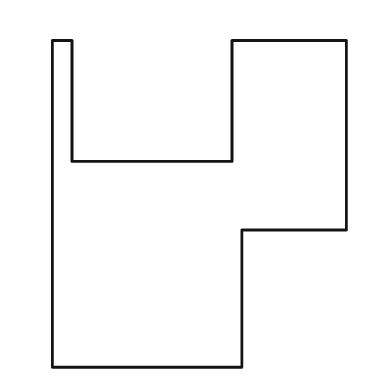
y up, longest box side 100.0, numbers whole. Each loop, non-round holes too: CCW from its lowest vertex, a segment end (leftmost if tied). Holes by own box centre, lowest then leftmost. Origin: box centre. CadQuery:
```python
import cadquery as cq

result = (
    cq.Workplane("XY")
    .moveTo(-45.0, -50.0)
    .lineTo(13.0, -50.0)
    .lineTo(13.0, -8.0)
    .lineTo(45.0, -8.0)
    .lineTo(45.0, 50.0)
    .lineTo(10.0, 50.0)
    .lineTo(10.0, 13.0)
    .lineTo(-39.0, 13.0)
    .lineTo(-39.0, 50.0)
    .lineTo(-45.0, 50.0)
    .close()
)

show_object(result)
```